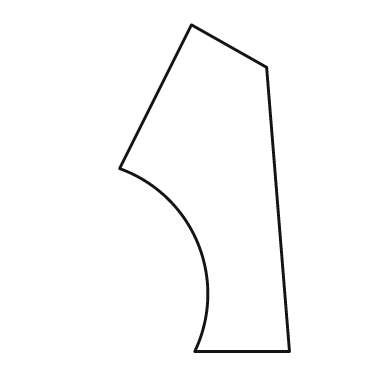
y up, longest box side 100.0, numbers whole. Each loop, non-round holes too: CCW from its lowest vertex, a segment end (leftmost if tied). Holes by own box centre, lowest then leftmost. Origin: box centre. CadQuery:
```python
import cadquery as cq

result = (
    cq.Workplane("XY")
    .moveTo(-3.0, -50.0)
    .lineTo(26.0, -50.0)
    .lineTo(19.0, 37.0)
    .lineTo(-4.0, 50.0)
    .lineTo(-26.0, 6.0)
    .threePointArc((-2.0, -17.0), (-3.0, -50.0))
    .close()
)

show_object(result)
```